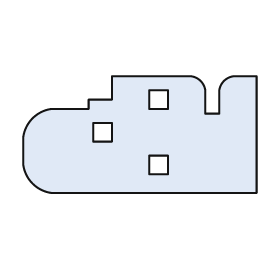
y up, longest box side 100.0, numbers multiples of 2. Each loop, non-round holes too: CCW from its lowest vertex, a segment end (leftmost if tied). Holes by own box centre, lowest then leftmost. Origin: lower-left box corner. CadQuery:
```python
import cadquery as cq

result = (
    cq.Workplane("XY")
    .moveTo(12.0, 0.0)
    .lineTo(100.0, 0.0)
    .lineTo(100.0, 50.0)
    .lineTo(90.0, 50.0)
    .threePointArc((86.0, 48.0), (84.0, 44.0))
    .lineTo(84.0, 34.0)
    .lineTo(78.0, 34.0)
    .lineTo(78.0, 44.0)
    .threePointArc((76.0, 48.0), (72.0, 50.0))
    .lineTo(38.0, 50.0)
    .lineTo(38.0, 40.0)
    .lineTo(28.0, 40.0)
    .lineTo(28.0, 36.0)
    .lineTo(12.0, 36.0)
    .threePointArc((4.0, 32.0), (0.0, 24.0))
    .lineTo(0.0, 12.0)
    .threePointArc((4.0, 4.0), (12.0, 0.0))
    .close()
    .moveTo(54.0, 8.0)
    .lineTo(62.0, 8.0)
    .lineTo(62.0, 16.0)
    .lineTo(54.0, 16.0)
    .close()
    .moveTo(30.0, 22.0)
    .lineTo(38.0, 22.0)
    .lineTo(38.0, 30.0)
    .lineTo(30.0, 30.0)
    .close()
    .moveTo(54.0, 36.0)
    .lineTo(62.0, 36.0)
    .lineTo(62.0, 44.0)
    .lineTo(54.0, 44.0)
    .close()
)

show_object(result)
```